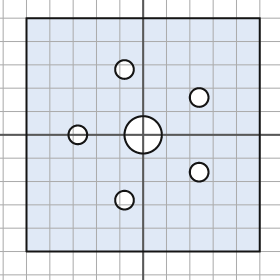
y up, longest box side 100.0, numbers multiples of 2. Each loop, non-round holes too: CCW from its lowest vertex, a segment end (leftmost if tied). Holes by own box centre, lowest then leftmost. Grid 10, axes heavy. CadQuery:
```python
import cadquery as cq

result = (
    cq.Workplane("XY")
    .moveTo(-50.0, -50.0)
    .lineTo(50.0, -50.0)
    .lineTo(50.0, 50.0)
    .lineTo(-50.0, 50.0)
    .close()
    .moveTo(-8.0, -28.0)
    .circle(4.0)
    .moveTo(24.0, -16.0)
    .circle(4.0)
    .moveTo(-28.0, 0.0)
    .circle(4.0)
    .moveTo(0.0, 0.0)
    .circle(8.0)
    .moveTo(24.0, 16.0)
    .circle(4.0)
    .moveTo(-8.0, 28.0)
    .circle(4.0)
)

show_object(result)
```